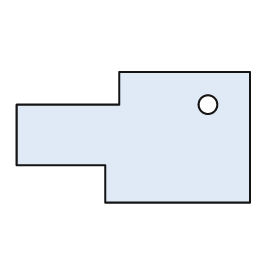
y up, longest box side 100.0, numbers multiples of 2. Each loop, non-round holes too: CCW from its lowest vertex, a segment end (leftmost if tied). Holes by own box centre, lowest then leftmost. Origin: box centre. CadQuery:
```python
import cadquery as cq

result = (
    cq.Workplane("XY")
    .moveTo(-12.0, -28.0)
    .lineTo(50.0, -28.0)
    .lineTo(50.0, 28.0)
    .lineTo(-6.0, 28.0)
    .lineTo(-6.0, 14.0)
    .lineTo(-50.0, 14.0)
    .lineTo(-50.0, -12.0)
    .lineTo(-12.0, -12.0)
    .close()
    .moveTo(32.0, 14.0)
    .circle(4.0)
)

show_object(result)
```